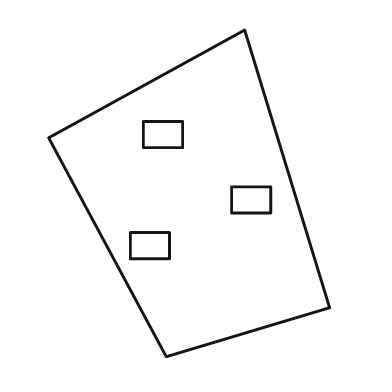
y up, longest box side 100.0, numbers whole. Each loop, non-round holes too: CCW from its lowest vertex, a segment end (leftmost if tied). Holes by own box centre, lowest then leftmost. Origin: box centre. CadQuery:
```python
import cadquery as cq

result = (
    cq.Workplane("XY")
    .moveTo(-7.0, -50.0)
    .lineTo(43.0, -35.0)
    .lineTo(17.0, 50.0)
    .lineTo(-43.0, 17.0)
    .close()
    .moveTo(-18.0, -20.0)
    .lineTo(-6.0, -20.0)
    .lineTo(-6.0, -12.0)
    .lineTo(-18.0, -12.0)
    .close()
    .moveTo(13.0, -6.0)
    .lineTo(25.0, -6.0)
    .lineTo(25.0, 2.0)
    .lineTo(13.0, 2.0)
    .close()
    .moveTo(-14.0, 14.0)
    .lineTo(-2.0, 14.0)
    .lineTo(-2.0, 22.0)
    .lineTo(-14.0, 22.0)
    .close()
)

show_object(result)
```